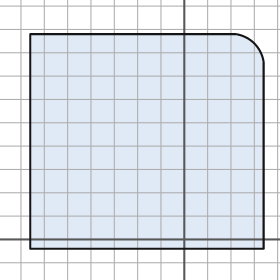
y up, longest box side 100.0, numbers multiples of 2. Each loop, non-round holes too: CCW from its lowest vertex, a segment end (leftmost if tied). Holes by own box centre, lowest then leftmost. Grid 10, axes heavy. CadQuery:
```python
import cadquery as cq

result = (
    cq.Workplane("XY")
    .moveTo(-66.0, -4.0)
    .lineTo(34.0, -4.0)
    .lineTo(34.0, 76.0)
    .threePointArc((30.0, 84.0), (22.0, 88.0))
    .lineTo(-66.0, 88.0)
    .close()
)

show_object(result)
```